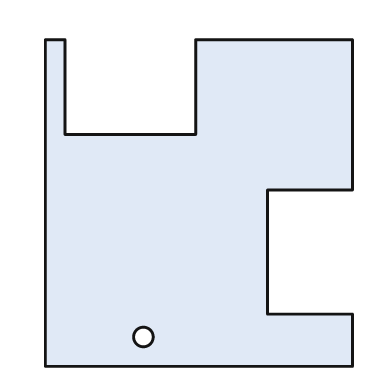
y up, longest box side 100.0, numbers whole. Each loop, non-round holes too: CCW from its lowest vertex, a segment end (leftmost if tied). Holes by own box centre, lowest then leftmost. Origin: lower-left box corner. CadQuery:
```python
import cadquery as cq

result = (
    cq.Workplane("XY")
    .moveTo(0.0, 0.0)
    .lineTo(94.0, 0.0)
    .lineTo(94.0, 16.0)
    .lineTo(68.0, 16.0)
    .lineTo(68.0, 54.0)
    .lineTo(94.0, 54.0)
    .lineTo(94.0, 100.0)
    .lineTo(46.0, 100.0)
    .lineTo(46.0, 71.0)
    .lineTo(6.0, 71.0)
    .lineTo(6.0, 100.0)
    .lineTo(0.0, 100.0)
    .close()
    .moveTo(30.0, 9.0)
    .circle(3.0)
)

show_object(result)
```